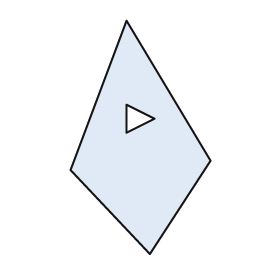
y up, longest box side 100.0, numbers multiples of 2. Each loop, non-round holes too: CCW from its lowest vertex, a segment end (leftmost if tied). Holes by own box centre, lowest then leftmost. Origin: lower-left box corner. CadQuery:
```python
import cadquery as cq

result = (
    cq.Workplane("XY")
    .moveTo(34.0, 0.0)
    .lineTo(60.0, 40.0)
    .lineTo(24.0, 100.0)
    .lineTo(0.0, 36.0)
    .close()
    .moveTo(24.0, 52.0)
    .lineTo(36.0, 58.0)
    .lineTo(24.0, 64.0)
    .close()
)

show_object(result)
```